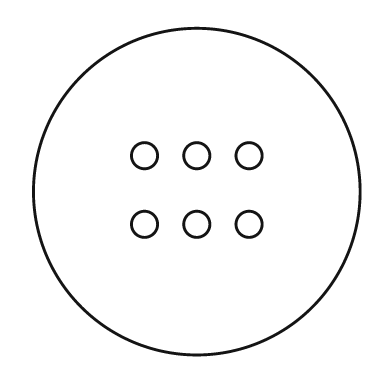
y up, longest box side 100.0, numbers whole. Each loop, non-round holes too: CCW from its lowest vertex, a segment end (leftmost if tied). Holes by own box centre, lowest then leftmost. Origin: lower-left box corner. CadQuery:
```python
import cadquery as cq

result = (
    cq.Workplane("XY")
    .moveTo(50.0, 50.0)
    .circle(50.0)
    .moveTo(34.0, 40.0)
    .circle(4.0)
    .moveTo(50.0, 40.0)
    .circle(4.0)
    .moveTo(66.0, 40.0)
    .circle(4.0)
    .moveTo(34.0, 61.0)
    .circle(4.0)
    .moveTo(50.0, 61.0)
    .circle(4.0)
    .moveTo(66.0, 61.0)
    .circle(4.0)
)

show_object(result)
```